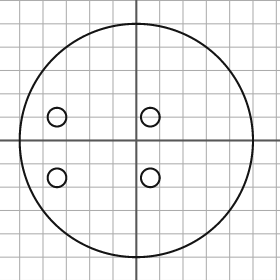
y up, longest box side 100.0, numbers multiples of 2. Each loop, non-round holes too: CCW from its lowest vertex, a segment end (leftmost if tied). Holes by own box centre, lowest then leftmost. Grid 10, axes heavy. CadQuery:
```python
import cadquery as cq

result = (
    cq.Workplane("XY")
    .moveTo(0.0, 0.0)
    .circle(50.0)
    .moveTo(-34.0, -16.0)
    .circle(4.0)
    .moveTo(6.0, -16.0)
    .circle(4.0)
    .moveTo(-34.0, 10.0)
    .circle(4.0)
    .moveTo(6.0, 10.0)
    .circle(4.0)
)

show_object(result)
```